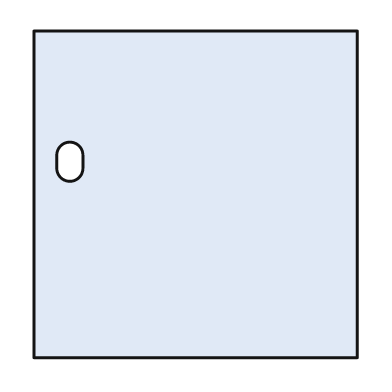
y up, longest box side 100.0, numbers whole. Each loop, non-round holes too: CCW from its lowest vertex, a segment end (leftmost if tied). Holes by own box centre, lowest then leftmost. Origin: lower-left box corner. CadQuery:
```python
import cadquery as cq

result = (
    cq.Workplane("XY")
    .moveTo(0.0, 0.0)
    .lineTo(99.0, 0.0)
    .lineTo(99.0, 100.0)
    .lineTo(0.0, 100.0)
    .close()
    .moveTo(7.0, 58.0)
    .threePointArc((11.0, 54.0), (15.0, 58.0))
    .lineTo(15.0, 62.0)
    .threePointArc((11.0, 66.0), (7.0, 62.0))
    .close()
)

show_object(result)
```